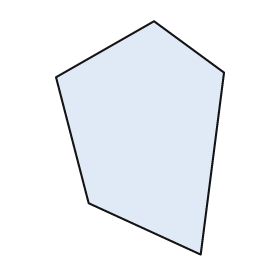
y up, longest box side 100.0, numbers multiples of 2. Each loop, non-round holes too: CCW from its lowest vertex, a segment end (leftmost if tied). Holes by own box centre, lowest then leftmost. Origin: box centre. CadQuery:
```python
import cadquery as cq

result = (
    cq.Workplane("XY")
    .moveTo(26.0, -50.0)
    .lineTo(36.0, 28.0)
    .lineTo(6.0, 50.0)
    .lineTo(-36.0, 26.0)
    .lineTo(-22.0, -28.0)
    .close()
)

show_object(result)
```